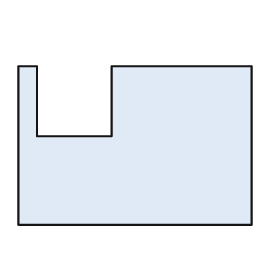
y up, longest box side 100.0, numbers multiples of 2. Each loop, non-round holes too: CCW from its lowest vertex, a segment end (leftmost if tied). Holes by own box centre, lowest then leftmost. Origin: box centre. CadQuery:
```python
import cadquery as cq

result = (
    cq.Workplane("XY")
    .moveTo(-50.0, -34.0)
    .lineTo(50.0, -34.0)
    .lineTo(50.0, 34.0)
    .lineTo(-10.0, 34.0)
    .lineTo(-10.0, 4.0)
    .lineTo(-42.0, 4.0)
    .lineTo(-42.0, 34.0)
    .lineTo(-50.0, 34.0)
    .close()
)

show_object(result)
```